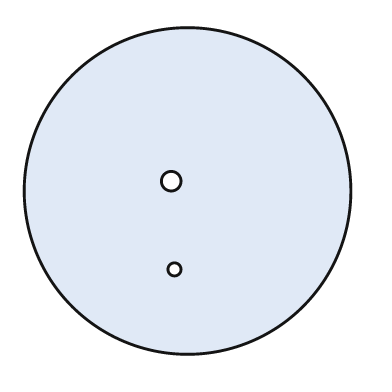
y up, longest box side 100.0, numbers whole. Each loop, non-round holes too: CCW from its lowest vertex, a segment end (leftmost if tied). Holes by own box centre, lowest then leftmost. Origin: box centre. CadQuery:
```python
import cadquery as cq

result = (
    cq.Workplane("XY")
    .moveTo(0.0, 0.0)
    .circle(50.0)
    .moveTo(-4.0, -24.0)
    .circle(2.0)
    .moveTo(-5.0, 3.0)
    .circle(3.0)
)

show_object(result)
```